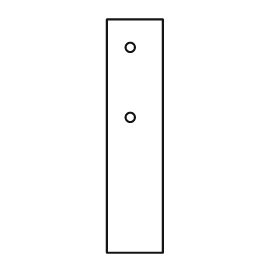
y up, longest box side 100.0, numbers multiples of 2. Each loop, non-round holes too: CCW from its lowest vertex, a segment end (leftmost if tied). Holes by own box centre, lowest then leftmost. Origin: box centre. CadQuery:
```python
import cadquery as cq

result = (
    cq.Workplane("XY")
    .moveTo(-12.0, -50.0)
    .lineTo(12.0, -50.0)
    .lineTo(12.0, 50.0)
    .lineTo(-12.0, 50.0)
    .close()
    .moveTo(-2.0, 8.0)
    .circle(2.0)
    .moveTo(-2.0, 38.0)
    .circle(2.0)
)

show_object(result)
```